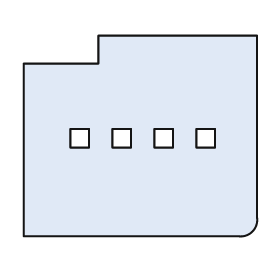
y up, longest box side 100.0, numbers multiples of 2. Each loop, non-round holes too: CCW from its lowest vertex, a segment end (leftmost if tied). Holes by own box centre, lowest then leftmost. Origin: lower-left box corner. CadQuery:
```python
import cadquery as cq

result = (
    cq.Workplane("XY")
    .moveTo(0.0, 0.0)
    .lineTo(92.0, 0.0)
    .threePointArc((98.0, 2.0), (100.0, 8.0))
    .lineTo(100.0, 86.0)
    .lineTo(32.0, 86.0)
    .lineTo(32.0, 74.0)
    .lineTo(0.0, 74.0)
    .close()
    .moveTo(20.0, 38.0)
    .lineTo(28.0, 38.0)
    .lineTo(28.0, 46.0)
    .lineTo(20.0, 46.0)
    .close()
    .moveTo(38.0, 38.0)
    .lineTo(46.0, 38.0)
    .lineTo(46.0, 46.0)
    .lineTo(38.0, 46.0)
    .close()
    .moveTo(56.0, 38.0)
    .lineTo(64.0, 38.0)
    .lineTo(64.0, 46.0)
    .lineTo(56.0, 46.0)
    .close()
    .moveTo(74.0, 38.0)
    .lineTo(82.0, 38.0)
    .lineTo(82.0, 46.0)
    .lineTo(74.0, 46.0)
    .close()
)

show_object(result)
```